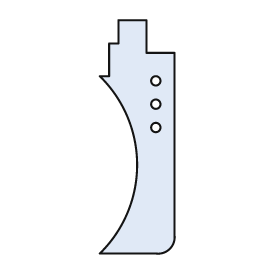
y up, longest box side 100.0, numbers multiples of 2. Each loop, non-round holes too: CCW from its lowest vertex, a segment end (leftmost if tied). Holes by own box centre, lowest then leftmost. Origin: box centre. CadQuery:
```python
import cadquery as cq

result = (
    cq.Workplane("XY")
    .moveTo(-16.0, -50.0)
    .lineTo(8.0, -50.0)
    .threePointArc((14.0, -48.0), (16.0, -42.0))
    .lineTo(16.0, 36.0)
    .lineTo(4.0, 36.0)
    .lineTo(4.0, 50.0)
    .lineTo(-8.0, 50.0)
    .lineTo(-8.0, 40.0)
    .lineTo(-12.0, 40.0)
    .lineTo(-12.0, 26.0)
    .lineTo(-16.0, 26.0)
    .threePointArc((0.0, -12.0), (-16.0, -50.0))
    .close()
    .moveTo(8.0, 4.0)
    .circle(2.0)
    .moveTo(8.0, 14.0)
    .circle(2.0)
    .moveTo(8.0, 24.0)
    .circle(2.0)
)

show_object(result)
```